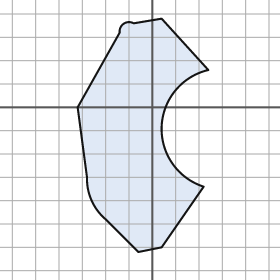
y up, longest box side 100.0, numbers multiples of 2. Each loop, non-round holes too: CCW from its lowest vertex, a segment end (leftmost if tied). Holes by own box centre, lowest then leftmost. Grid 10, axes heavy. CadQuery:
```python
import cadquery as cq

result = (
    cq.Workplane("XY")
    .moveTo(-6.0, -62.0)
    .lineTo(4.0, -60.0)
    .lineTo(22.0, -34.0)
    .threePointArc((4.0, -8.0), (24.0, 16.0))
    .lineTo(4.0, 38.0)
    .lineTo(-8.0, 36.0)
    .threePointArc((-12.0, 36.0), (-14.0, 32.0))
    .lineTo(-32.0, 0.0)
    .lineTo(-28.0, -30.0)
    .threePointArc((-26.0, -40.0), (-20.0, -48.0))
    .close()
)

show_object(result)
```